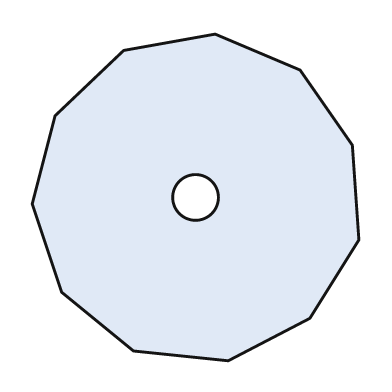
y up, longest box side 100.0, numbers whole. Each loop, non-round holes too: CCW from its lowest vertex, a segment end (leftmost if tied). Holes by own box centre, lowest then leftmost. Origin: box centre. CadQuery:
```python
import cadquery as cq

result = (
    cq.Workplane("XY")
    .moveTo(10.0, -50.0)
    .lineTo(35.0, -37.0)
    .lineTo(50.0, -13.0)
    .lineTo(48.0, 16.0)
    .lineTo(32.0, 39.0)
    .lineTo(6.0, 50.0)
    .lineTo(-22.0, 45.0)
    .lineTo(-43.0, 25.0)
    .lineTo(-50.0, -2.0)
    .lineTo(-41.0, -29.0)
    .lineTo(-19.0, -47.0)
    .close()
    .moveTo(0.0, 0.0)
    .circle(7.0)
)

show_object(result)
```